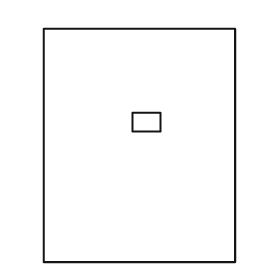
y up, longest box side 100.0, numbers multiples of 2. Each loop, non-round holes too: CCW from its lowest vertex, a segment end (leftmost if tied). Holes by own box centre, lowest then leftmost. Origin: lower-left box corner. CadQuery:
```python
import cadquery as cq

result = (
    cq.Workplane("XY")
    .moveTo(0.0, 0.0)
    .lineTo(82.0, 0.0)
    .lineTo(82.0, 100.0)
    .lineTo(0.0, 100.0)
    .close()
    .moveTo(38.0, 56.0)
    .lineTo(50.0, 56.0)
    .lineTo(50.0, 64.0)
    .lineTo(38.0, 64.0)
    .close()
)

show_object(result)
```